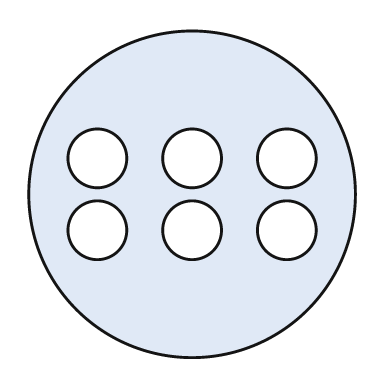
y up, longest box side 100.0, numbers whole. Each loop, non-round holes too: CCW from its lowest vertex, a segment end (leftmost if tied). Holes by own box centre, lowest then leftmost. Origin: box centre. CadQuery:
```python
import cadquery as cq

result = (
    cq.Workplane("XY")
    .moveTo(0.0, 0.0)
    .circle(50.0)
    .moveTo(-29.0, -11.0)
    .circle(9.0)
    .moveTo(0.0, -11.0)
    .circle(9.0)
    .moveTo(29.0, -11.0)
    .circle(9.0)
    .moveTo(-29.0, 11.0)
    .circle(9.0)
    .moveTo(0.0, 11.0)
    .circle(9.0)
    .moveTo(29.0, 11.0)
    .circle(9.0)
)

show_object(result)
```